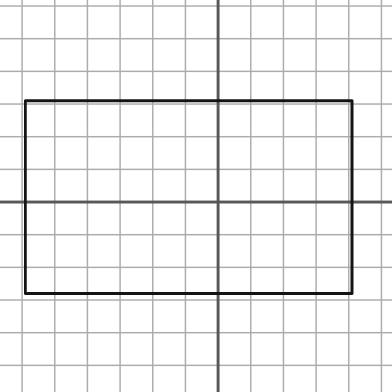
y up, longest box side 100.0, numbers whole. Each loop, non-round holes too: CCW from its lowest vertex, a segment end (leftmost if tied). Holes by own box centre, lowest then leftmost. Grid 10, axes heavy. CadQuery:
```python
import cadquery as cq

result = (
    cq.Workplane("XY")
    .moveTo(-59.0, -28.0)
    .lineTo(41.0, -28.0)
    .lineTo(41.0, 31.0)
    .lineTo(-59.0, 31.0)
    .close()
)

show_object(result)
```